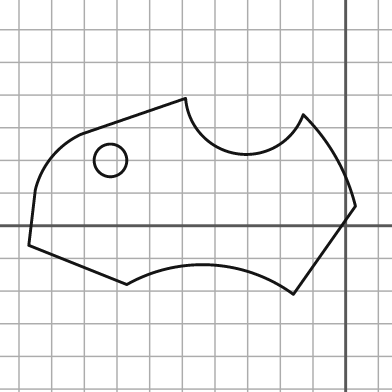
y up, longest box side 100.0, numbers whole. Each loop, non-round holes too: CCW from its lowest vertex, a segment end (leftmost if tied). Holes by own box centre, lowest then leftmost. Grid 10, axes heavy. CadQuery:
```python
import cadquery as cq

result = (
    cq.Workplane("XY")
    .moveTo(-16.0, -21.0)
    .lineTo(3.0, 6.0)
    .threePointArc((-3.0, 21.0), (-13.0, 34.0))
    .threePointArc((-33.0, 22.0), (-49.0, 39.0))
    .lineTo(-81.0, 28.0)
    .threePointArc((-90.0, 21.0), (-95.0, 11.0))
    .lineTo(-97.0, -6.0)
    .lineTo(-67.0, -18.0)
    .threePointArc((-41.0, -12.0), (-16.0, -21.0))
    .close()
    .moveTo(-72.0, 20.0)
    .circle(5.0)
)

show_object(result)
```